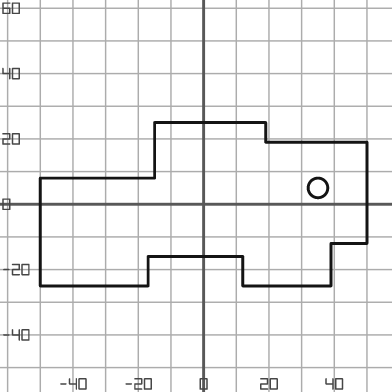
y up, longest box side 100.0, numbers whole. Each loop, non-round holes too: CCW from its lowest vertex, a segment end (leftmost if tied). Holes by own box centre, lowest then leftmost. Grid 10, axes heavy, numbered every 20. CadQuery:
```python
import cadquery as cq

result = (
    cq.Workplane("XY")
    .moveTo(-50.0, -25.0)
    .lineTo(-17.0, -25.0)
    .lineTo(-17.0, -16.0)
    .lineTo(12.0, -16.0)
    .lineTo(12.0, -25.0)
    .lineTo(39.0, -25.0)
    .lineTo(39.0, -12.0)
    .lineTo(50.0, -12.0)
    .lineTo(50.0, 19.0)
    .lineTo(19.0, 19.0)
    .lineTo(19.0, 25.0)
    .lineTo(-15.0, 25.0)
    .lineTo(-15.0, 8.0)
    .lineTo(-50.0, 8.0)
    .close()
    .moveTo(35.0, 5.0)
    .circle(3.0)
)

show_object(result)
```